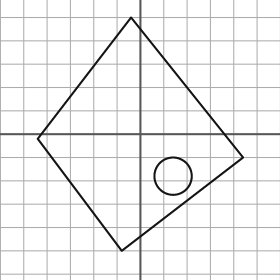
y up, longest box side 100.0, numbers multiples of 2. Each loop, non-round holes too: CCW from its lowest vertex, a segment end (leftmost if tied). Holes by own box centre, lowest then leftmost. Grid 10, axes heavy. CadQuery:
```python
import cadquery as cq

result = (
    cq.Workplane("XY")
    .moveTo(-8.0, -50.0)
    .lineTo(44.0, -10.0)
    .lineTo(-4.0, 50.0)
    .lineTo(-44.0, -2.0)
    .close()
    .moveTo(14.0, -18.0)
    .circle(8.0)
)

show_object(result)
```